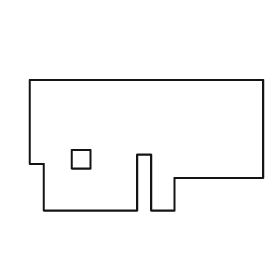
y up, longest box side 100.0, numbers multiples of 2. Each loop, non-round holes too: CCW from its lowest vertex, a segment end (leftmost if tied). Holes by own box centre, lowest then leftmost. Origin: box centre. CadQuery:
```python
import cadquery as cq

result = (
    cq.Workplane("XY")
    .moveTo(-44.0, -28.0)
    .lineTo(-4.0, -28.0)
    .lineTo(-4.0, -4.0)
    .lineTo(2.0, -4.0)
    .lineTo(2.0, -28.0)
    .lineTo(12.0, -28.0)
    .lineTo(12.0, -14.0)
    .lineTo(50.0, -14.0)
    .lineTo(50.0, 28.0)
    .lineTo(-50.0, 28.0)
    .lineTo(-50.0, -8.0)
    .lineTo(-44.0, -8.0)
    .close()
    .moveTo(-32.0, -10.0)
    .lineTo(-24.0, -10.0)
    .lineTo(-24.0, -2.0)
    .lineTo(-32.0, -2.0)
    .close()
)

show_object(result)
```